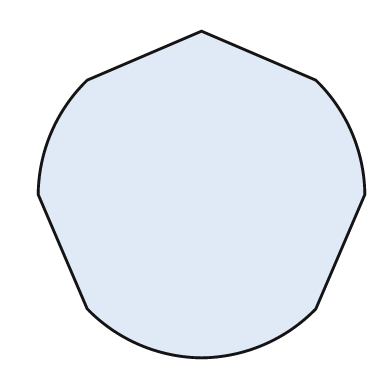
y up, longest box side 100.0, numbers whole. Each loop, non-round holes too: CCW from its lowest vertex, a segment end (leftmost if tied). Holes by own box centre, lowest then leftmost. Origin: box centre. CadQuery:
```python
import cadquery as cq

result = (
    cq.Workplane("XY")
    .moveTo(0.0, -50.0)
    .threePointArc((19.0, -46.0), (35.0, -35.0))
    .lineTo(50.0, 0.0)
    .threePointArc((46.0, 19.0), (35.0, 35.0))
    .lineTo(0.0, 50.0)
    .lineTo(-35.0, 35.0)
    .threePointArc((-46.0, 19.0), (-50.0, 0.0))
    .lineTo(-35.0, -35.0)
    .threePointArc((-19.0, -46.0), (0.0, -50.0))
    .close()
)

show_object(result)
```